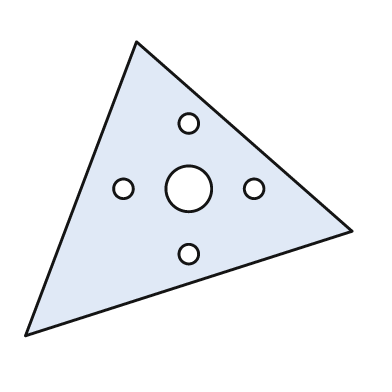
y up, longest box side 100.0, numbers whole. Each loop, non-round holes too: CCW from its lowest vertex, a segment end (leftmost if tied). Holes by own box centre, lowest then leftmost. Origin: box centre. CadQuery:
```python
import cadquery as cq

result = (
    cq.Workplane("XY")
    .moveTo(-50.0, -45.0)
    .lineTo(50.0, -13.0)
    .lineTo(-16.0, 45.0)
    .close()
    .moveTo(0.0, -20.0)
    .circle(3.0)
    .moveTo(-20.0, 0.0)
    .circle(3.0)
    .moveTo(0.0, 0.0)
    .circle(7.0)
    .moveTo(20.0, 0.0)
    .circle(3.0)
    .moveTo(0.0, 20.0)
    .circle(3.0)
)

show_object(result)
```